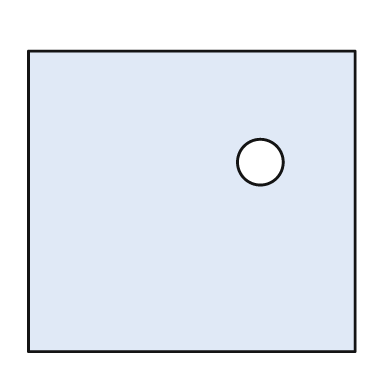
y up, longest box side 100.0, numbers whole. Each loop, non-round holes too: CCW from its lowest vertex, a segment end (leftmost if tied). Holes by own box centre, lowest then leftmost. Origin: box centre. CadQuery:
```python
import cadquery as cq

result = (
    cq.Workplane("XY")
    .moveTo(-50.0, -46.0)
    .lineTo(50.0, -46.0)
    .lineTo(50.0, 46.0)
    .lineTo(-50.0, 46.0)
    .close()
    .moveTo(21.0, 12.0)
    .circle(7.0)
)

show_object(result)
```